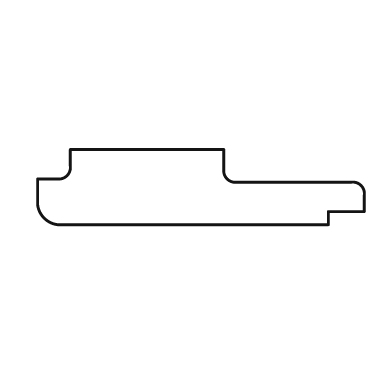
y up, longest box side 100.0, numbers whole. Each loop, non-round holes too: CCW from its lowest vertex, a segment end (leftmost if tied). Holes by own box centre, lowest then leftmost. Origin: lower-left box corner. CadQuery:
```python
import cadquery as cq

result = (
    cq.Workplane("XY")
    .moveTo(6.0, 0.0)
    .lineTo(89.0, 0.0)
    .lineTo(89.0, 4.0)
    .lineTo(100.0, 4.0)
    .lineTo(100.0, 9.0)
    .threePointArc((99.0, 12.0), (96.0, 13.0))
    .lineTo(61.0, 13.0)
    .threePointArc((58.0, 14.0), (57.0, 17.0))
    .lineTo(57.0, 23.0)
    .lineTo(10.0, 23.0)
    .lineTo(10.0, 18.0)
    .threePointArc((9.0, 15.0), (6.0, 14.0))
    .lineTo(0.0, 14.0)
    .lineTo(0.0, 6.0)
    .threePointArc((2.0, 2.0), (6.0, 0.0))
    .close()
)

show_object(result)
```